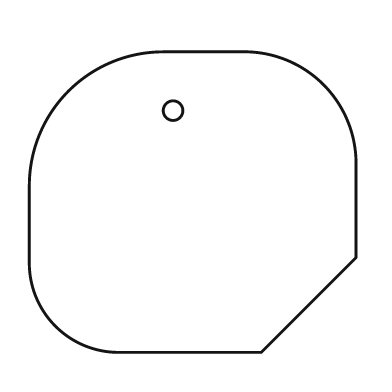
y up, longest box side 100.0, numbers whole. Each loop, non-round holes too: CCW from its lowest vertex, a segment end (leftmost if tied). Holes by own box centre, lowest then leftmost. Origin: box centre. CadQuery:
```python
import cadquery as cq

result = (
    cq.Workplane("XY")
    .moveTo(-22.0, -46.0)
    .lineTo(21.0, -46.0)
    .lineTo(50.0, -17.0)
    .lineTo(50.0, 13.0)
    .threePointArc((40.0, 36.0), (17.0, 46.0))
    .lineTo(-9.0, 46.0)
    .threePointArc((-38.0, 34.0), (-50.0, 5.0))
    .lineTo(-50.0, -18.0)
    .threePointArc((-42.0, -38.0), (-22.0, -46.0))
    .close()
    .moveTo(-6.0, 28.0)
    .circle(3.0)
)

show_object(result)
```